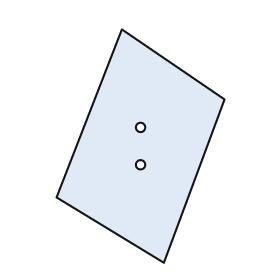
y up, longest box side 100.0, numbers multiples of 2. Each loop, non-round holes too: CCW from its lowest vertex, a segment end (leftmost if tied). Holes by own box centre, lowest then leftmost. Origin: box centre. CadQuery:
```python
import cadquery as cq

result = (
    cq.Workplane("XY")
    .moveTo(10.0, -50.0)
    .lineTo(36.0, 20.0)
    .lineTo(-8.0, 50.0)
    .lineTo(-36.0, -22.0)
    .close()
    .moveTo(0.0, -8.0)
    .circle(2.0)
    .moveTo(0.0, 8.0)
    .circle(2.0)
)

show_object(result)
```